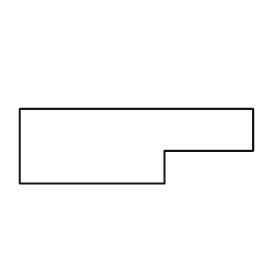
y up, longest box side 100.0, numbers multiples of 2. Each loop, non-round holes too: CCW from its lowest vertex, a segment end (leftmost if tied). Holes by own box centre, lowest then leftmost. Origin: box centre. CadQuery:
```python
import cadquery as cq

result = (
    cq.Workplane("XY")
    .moveTo(-50.0, -16.0)
    .lineTo(12.0, -16.0)
    .lineTo(12.0, -2.0)
    .lineTo(50.0, -2.0)
    .lineTo(50.0, 16.0)
    .lineTo(-50.0, 16.0)
    .close()
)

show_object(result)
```